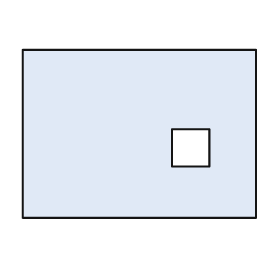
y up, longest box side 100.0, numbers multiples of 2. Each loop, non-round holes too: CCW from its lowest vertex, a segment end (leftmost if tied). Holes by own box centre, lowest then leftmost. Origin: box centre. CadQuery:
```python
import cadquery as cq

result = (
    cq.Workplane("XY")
    .moveTo(-50.0, -36.0)
    .lineTo(50.0, -36.0)
    .lineTo(50.0, 36.0)
    .lineTo(-50.0, 36.0)
    .close()
    .moveTo(14.0, -14.0)
    .lineTo(30.0, -14.0)
    .lineTo(30.0, 2.0)
    .lineTo(14.0, 2.0)
    .close()
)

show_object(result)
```